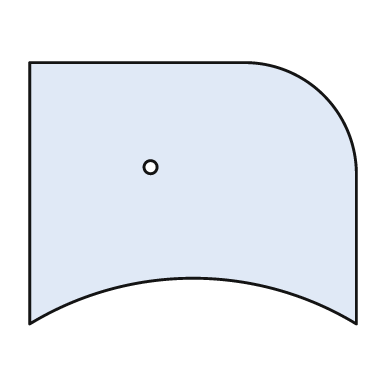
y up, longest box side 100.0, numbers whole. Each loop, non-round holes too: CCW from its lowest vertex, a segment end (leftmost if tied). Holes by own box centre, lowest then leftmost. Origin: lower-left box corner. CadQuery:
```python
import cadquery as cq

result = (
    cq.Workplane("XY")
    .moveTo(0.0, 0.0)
    .threePointArc((50.0, 14.0), (100.0, 0.0))
    .lineTo(100.0, 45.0)
    .threePointArc((90.0, 70.0), (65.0, 80.0))
    .lineTo(0.0, 80.0)
    .close()
    .moveTo(37.0, 48.0)
    .circle(2.0)
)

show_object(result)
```